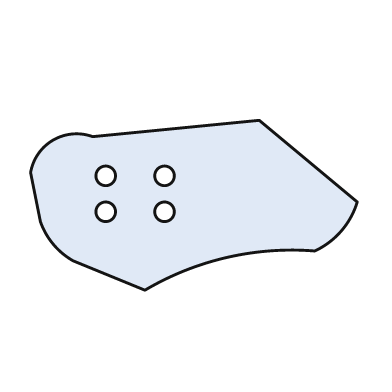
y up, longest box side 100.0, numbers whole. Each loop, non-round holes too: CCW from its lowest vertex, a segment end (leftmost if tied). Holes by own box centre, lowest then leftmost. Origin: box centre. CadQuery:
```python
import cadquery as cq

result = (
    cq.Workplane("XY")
    .moveTo(-15.0, -26.0)
    .threePointArc((10.0, -16.0), (37.0, -14.0))
    .threePointArc((45.0, -8.0), (50.0, 1.0))
    .lineTo(20.0, 26.0)
    .lineTo(-31.0, 21.0)
    .threePointArc((-43.0, 20.0), (-50.0, 10.0))
    .lineTo(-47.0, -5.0)
    .threePointArc((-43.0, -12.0), (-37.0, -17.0))
    .close()
    .moveTo(-27.0, -2.0)
    .circle(3.0)
    .moveTo(-9.0, -2.0)
    .circle(3.0)
    .moveTo(-27.0, 9.0)
    .circle(3.0)
    .moveTo(-9.0, 9.0)
    .circle(3.0)
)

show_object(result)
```